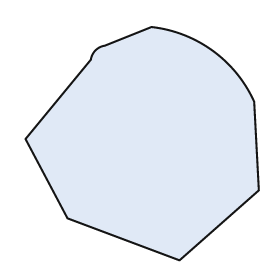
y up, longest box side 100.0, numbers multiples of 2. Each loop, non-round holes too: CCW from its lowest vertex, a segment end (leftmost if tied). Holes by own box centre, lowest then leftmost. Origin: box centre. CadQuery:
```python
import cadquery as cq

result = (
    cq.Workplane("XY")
    .moveTo(16.0, -50.0)
    .lineTo(50.0, -20.0)
    .lineTo(48.0, 18.0)
    .threePointArc((30.0, 40.0), (4.0, 50.0))
    .lineTo(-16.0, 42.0)
    .threePointArc((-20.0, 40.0), (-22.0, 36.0))
    .lineTo(-50.0, 2.0)
    .lineTo(-32.0, -32.0)
    .close()
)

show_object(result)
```